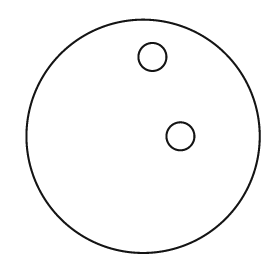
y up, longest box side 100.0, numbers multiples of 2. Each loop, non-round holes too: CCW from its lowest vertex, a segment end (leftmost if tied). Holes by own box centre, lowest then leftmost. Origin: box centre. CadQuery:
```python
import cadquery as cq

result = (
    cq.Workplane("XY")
    .moveTo(0.0, 0.0)
    .circle(50.0)
    .moveTo(16.0, 0.0)
    .circle(6.0)
    .moveTo(4.0, 34.0)
    .circle(6.0)
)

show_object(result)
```